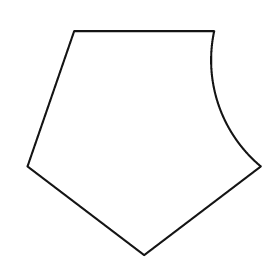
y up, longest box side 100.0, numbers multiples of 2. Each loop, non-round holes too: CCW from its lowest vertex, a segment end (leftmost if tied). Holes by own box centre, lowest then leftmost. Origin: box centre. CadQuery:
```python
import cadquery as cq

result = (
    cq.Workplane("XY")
    .moveTo(0.0, -48.0)
    .lineTo(50.0, -10.0)
    .threePointArc((32.0, 16.0), (30.0, 48.0))
    .lineTo(-30.0, 48.0)
    .lineTo(-50.0, -10.0)
    .close()
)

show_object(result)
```